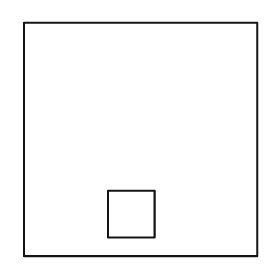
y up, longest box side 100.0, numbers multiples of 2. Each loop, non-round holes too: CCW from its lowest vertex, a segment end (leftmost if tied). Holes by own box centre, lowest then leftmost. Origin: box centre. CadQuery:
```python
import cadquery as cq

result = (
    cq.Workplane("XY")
    .moveTo(-50.0, -50.0)
    .lineTo(50.0, -50.0)
    .lineTo(50.0, 50.0)
    .lineTo(-50.0, 50.0)
    .close()
    .moveTo(-14.0, -42.0)
    .lineTo(6.0, -42.0)
    .lineTo(6.0, -22.0)
    .lineTo(-14.0, -22.0)
    .close()
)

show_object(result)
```